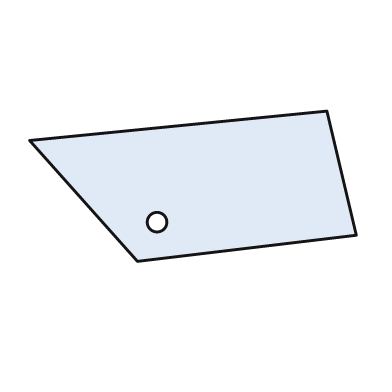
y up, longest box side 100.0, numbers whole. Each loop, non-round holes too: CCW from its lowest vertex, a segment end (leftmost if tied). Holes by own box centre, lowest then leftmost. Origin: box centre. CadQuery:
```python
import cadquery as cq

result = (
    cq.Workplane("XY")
    .moveTo(-17.0, -23.0)
    .lineTo(50.0, -15.0)
    .lineTo(41.0, 23.0)
    .lineTo(-50.0, 14.0)
    .close()
    .moveTo(-11.0, -11.0)
    .circle(3.0)
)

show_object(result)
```